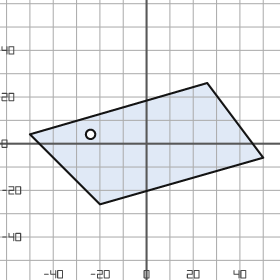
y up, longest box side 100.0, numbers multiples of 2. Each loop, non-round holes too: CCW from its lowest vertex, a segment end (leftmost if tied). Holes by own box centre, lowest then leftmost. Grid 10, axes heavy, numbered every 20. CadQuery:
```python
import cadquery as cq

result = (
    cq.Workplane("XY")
    .moveTo(-20.0, -26.0)
    .lineTo(50.0, -6.0)
    .lineTo(26.0, 26.0)
    .lineTo(-50.0, 4.0)
    .close()
    .moveTo(-24.0, 4.0)
    .circle(2.0)
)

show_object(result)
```